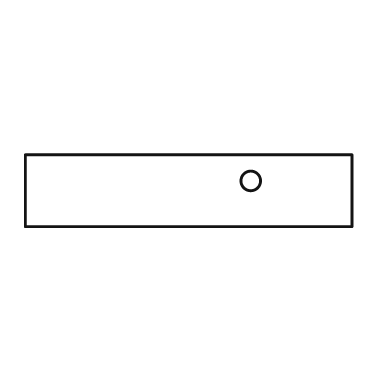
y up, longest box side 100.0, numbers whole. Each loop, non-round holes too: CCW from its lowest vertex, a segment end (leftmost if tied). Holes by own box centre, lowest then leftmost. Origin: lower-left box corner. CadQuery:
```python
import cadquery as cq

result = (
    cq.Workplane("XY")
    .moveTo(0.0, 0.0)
    .lineTo(100.0, 0.0)
    .lineTo(100.0, 22.0)
    .lineTo(0.0, 22.0)
    .close()
    .moveTo(69.0, 14.0)
    .circle(3.0)
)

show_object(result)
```